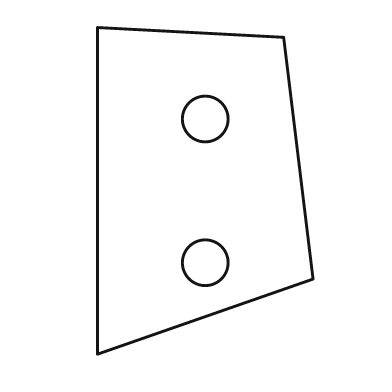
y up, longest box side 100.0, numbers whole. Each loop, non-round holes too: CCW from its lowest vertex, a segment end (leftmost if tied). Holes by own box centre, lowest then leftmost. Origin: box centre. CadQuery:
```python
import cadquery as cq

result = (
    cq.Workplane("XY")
    .moveTo(-33.0, -50.0)
    .lineTo(33.0, -27.0)
    .lineTo(24.0, 47.0)
    .lineTo(-33.0, 50.0)
    .close()
    .moveTo(0.0, -22.0)
    .circle(7.0)
    .moveTo(0.0, 22.0)
    .circle(7.0)
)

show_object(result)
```